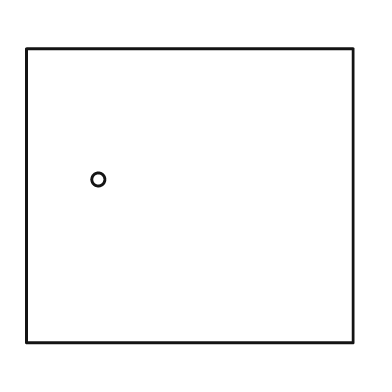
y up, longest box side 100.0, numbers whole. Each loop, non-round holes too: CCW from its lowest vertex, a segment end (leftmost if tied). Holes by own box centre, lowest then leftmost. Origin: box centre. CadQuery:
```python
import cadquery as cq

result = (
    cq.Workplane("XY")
    .moveTo(-50.0, -45.0)
    .lineTo(50.0, -45.0)
    .lineTo(50.0, 45.0)
    .lineTo(-50.0, 45.0)
    .close()
    .moveTo(-28.0, 5.0)
    .circle(2.0)
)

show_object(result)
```